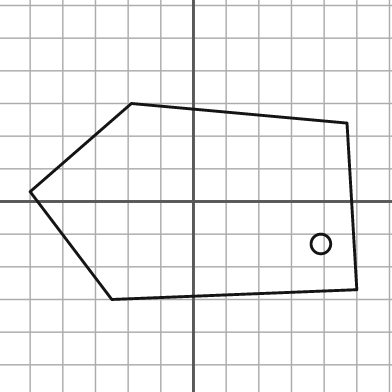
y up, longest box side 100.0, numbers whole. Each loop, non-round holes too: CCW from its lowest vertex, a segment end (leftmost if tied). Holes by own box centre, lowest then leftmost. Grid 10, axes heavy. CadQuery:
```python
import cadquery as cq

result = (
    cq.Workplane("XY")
    .moveTo(-25.0, -30.0)
    .lineTo(50.0, -27.0)
    .lineTo(47.0, 24.0)
    .lineTo(-19.0, 30.0)
    .lineTo(-50.0, 3.0)
    .close()
    .moveTo(39.0, -13.0)
    .circle(3.0)
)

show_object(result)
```